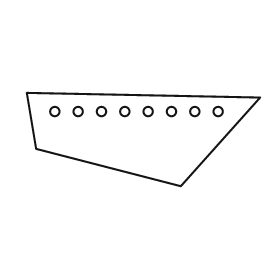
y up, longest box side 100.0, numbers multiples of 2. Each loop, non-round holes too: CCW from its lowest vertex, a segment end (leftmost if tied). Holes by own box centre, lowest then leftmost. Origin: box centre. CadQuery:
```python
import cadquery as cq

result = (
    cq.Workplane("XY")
    .moveTo(16.0, -20.0)
    .lineTo(50.0, 18.0)
    .lineTo(-50.0, 20.0)
    .lineTo(-46.0, -4.0)
    .close()
    .moveTo(-38.0, 12.0)
    .circle(2.0)
    .moveTo(-28.0, 12.0)
    .circle(2.0)
    .moveTo(-18.0, 12.0)
    .circle(2.0)
    .moveTo(-8.0, 12.0)
    .circle(2.0)
    .moveTo(2.0, 12.0)
    .circle(2.0)
    .moveTo(12.0, 12.0)
    .circle(2.0)
    .moveTo(22.0, 12.0)
    .circle(2.0)
    .moveTo(32.0, 12.0)
    .circle(2.0)
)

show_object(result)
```